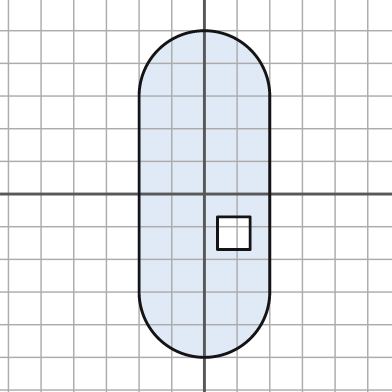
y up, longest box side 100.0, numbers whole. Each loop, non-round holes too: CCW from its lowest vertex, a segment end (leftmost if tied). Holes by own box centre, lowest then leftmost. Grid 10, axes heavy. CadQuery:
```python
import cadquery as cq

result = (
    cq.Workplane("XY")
    .moveTo(-20.0, -30.0)
    .threePointArc((0.0, -50.0), (20.0, -30.0))
    .lineTo(20.0, 30.0)
    .threePointArc((0.0, 50.0), (-20.0, 30.0))
    .close()
    .moveTo(4.0, -17.0)
    .lineTo(14.0, -17.0)
    .lineTo(14.0, -7.0)
    .lineTo(4.0, -7.0)
    .close()
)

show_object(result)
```